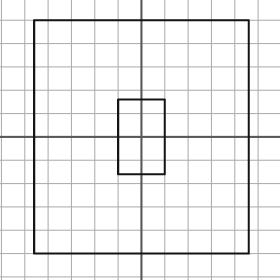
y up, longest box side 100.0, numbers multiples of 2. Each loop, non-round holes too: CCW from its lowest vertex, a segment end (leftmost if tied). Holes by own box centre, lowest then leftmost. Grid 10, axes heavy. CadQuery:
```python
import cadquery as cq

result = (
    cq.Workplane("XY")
    .moveTo(-46.0, -50.0)
    .lineTo(46.0, -50.0)
    .lineTo(46.0, 50.0)
    .lineTo(-46.0, 50.0)
    .close()
    .moveTo(-10.0, -16.0)
    .lineTo(10.0, -16.0)
    .lineTo(10.0, 16.0)
    .lineTo(-10.0, 16.0)
    .close()
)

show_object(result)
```